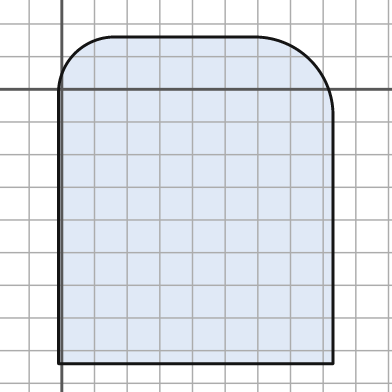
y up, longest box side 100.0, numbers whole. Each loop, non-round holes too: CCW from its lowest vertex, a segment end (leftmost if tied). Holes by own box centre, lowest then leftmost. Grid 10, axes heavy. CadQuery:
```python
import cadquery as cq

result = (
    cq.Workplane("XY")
    .moveTo(-1.0, -84.0)
    .lineTo(83.0, -84.0)
    .lineTo(83.0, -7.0)
    .threePointArc((76.0, 9.0), (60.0, 16.0))
    .lineTo(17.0, 16.0)
    .threePointArc((4.0, 11.0), (-1.0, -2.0))
    .close()
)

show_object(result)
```